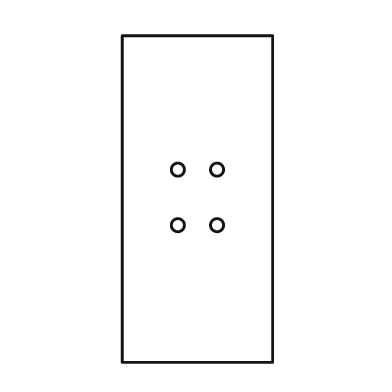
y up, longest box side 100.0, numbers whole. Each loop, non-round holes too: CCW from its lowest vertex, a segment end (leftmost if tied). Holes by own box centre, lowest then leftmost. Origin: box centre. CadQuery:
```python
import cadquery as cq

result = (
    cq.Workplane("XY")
    .moveTo(-23.0, -50.0)
    .lineTo(23.0, -50.0)
    .lineTo(23.0, 50.0)
    .lineTo(-23.0, 50.0)
    .close()
    .moveTo(-6.0, -8.0)
    .circle(2.0)
    .moveTo(6.0, -8.0)
    .circle(2.0)
    .moveTo(-6.0, 9.0)
    .circle(2.0)
    .moveTo(6.0, 9.0)
    .circle(2.0)
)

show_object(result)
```